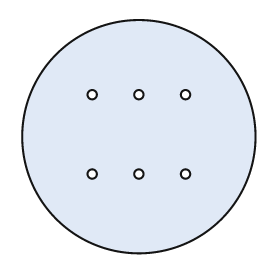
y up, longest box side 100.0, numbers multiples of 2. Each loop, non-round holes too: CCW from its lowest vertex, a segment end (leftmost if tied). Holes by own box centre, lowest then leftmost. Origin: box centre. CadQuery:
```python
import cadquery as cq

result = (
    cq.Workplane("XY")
    .moveTo(0.0, 0.0)
    .circle(50.0)
    .moveTo(-20.0, -16.0)
    .circle(2.0)
    .moveTo(0.0, -16.0)
    .circle(2.0)
    .moveTo(20.0, -16.0)
    .circle(2.0)
    .moveTo(-20.0, 18.0)
    .circle(2.0)
    .moveTo(0.0, 18.0)
    .circle(2.0)
    .moveTo(20.0, 18.0)
    .circle(2.0)
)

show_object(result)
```